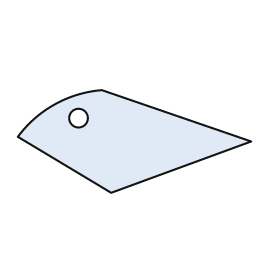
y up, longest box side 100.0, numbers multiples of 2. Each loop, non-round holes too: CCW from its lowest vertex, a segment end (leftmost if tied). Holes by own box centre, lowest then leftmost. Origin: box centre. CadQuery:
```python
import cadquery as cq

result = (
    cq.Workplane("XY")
    .moveTo(-10.0, -22.0)
    .lineTo(50.0, 0.0)
    .lineTo(-14.0, 22.0)
    .threePointArc((-34.0, 16.0), (-50.0, 2.0))
    .close()
    .moveTo(-24.0, 10.0)
    .circle(4.0)
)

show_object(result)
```